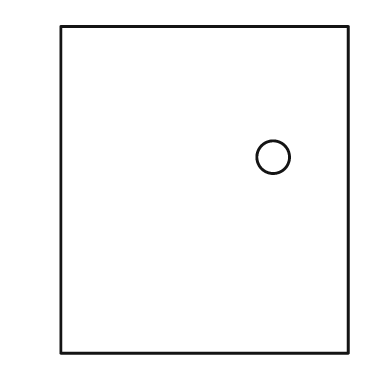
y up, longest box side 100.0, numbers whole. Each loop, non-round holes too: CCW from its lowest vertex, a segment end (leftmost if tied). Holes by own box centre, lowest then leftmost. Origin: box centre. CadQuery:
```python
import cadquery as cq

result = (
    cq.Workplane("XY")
    .moveTo(-44.0, -50.0)
    .lineTo(44.0, -50.0)
    .lineTo(44.0, 50.0)
    .lineTo(-44.0, 50.0)
    .close()
    .moveTo(21.0, 10.0)
    .circle(5.0)
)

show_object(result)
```